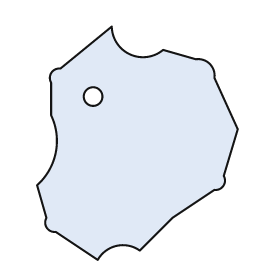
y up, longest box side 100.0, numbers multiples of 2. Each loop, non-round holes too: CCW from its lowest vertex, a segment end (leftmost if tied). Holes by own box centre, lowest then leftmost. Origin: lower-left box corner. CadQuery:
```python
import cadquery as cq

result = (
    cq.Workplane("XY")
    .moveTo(26.0, 0.0)
    .threePointArc((34.0, 6.0), (44.0, 4.0))
    .lineTo(58.0, 18.0)
    .lineTo(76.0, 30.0)
    .threePointArc((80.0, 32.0), (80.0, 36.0))
    .lineTo(86.0, 56.0)
    .lineTo(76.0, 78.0)
    .threePointArc((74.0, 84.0), (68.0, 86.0))
    .lineTo(54.0, 90.0)
    .threePointArc((40.0, 88.0), (32.0, 100.0))
    .lineTo(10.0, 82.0)
    .threePointArc((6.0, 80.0), (6.0, 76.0))
    .lineTo(6.0, 62.0)
    .threePointArc((8.0, 46.0), (0.0, 32.0))
    .lineTo(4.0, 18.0)
    .threePointArc((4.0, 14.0), (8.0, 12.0))
    .close()
    .moveTo(24.0, 70.0)
    .circle(4.0)
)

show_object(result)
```